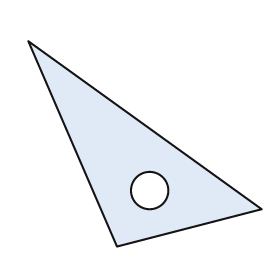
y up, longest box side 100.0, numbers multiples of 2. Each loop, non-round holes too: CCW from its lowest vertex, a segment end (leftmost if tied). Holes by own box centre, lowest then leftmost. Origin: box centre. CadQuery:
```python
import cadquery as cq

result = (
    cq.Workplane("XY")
    .moveTo(-12.0, -44.0)
    .lineTo(50.0, -28.0)
    .lineTo(-50.0, 44.0)
    .close()
    .moveTo(2.0, -20.0)
    .circle(8.0)
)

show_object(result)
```